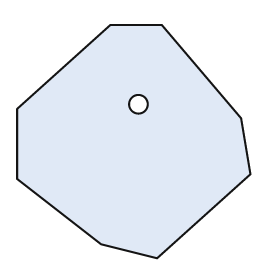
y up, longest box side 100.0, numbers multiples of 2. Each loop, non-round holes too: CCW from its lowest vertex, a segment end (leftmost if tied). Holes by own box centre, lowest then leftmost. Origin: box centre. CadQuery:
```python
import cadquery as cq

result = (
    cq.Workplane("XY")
    .moveTo(10.0, -50.0)
    .lineTo(50.0, -14.0)
    .lineTo(46.0, 10.0)
    .lineTo(12.0, 50.0)
    .lineTo(-10.0, 50.0)
    .lineTo(-50.0, 14.0)
    .lineTo(-50.0, -16.0)
    .lineTo(-14.0, -44.0)
    .close()
    .moveTo(2.0, 16.0)
    .circle(4.0)
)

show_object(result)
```